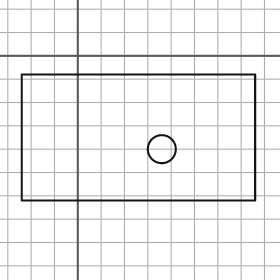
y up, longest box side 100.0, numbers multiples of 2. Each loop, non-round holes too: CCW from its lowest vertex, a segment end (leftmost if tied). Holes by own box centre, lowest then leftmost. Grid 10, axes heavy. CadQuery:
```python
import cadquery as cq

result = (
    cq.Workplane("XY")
    .moveTo(-24.0, -62.0)
    .lineTo(76.0, -62.0)
    .lineTo(76.0, -8.0)
    .lineTo(-24.0, -8.0)
    .close()
    .moveTo(36.0, -40.0)
    .circle(6.0)
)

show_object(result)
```